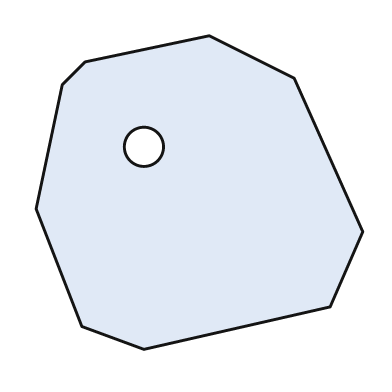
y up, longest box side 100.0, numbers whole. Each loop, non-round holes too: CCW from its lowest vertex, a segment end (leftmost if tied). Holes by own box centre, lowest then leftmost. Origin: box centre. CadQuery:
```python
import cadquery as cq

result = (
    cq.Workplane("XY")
    .moveTo(-17.0, -48.0)
    .lineTo(40.0, -35.0)
    .lineTo(50.0, -12.0)
    .lineTo(29.0, 35.0)
    .lineTo(3.0, 48.0)
    .lineTo(-35.0, 40.0)
    .lineTo(-42.0, 33.0)
    .lineTo(-50.0, -5.0)
    .lineTo(-36.0, -41.0)
    .close()
    .moveTo(-17.0, 14.0)
    .circle(6.0)
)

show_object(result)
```